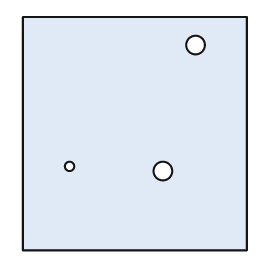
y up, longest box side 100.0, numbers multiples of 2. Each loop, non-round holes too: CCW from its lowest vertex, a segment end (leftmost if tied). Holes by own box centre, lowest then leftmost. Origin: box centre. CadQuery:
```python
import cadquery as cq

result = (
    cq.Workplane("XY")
    .moveTo(-48.0, -50.0)
    .lineTo(48.0, -50.0)
    .lineTo(48.0, 50.0)
    .lineTo(-48.0, 50.0)
    .close()
    .moveTo(12.0, -16.0)
    .circle(4.0)
    .moveTo(-28.0, -14.0)
    .circle(2.0)
    .moveTo(26.0, 38.0)
    .circle(4.0)
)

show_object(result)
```